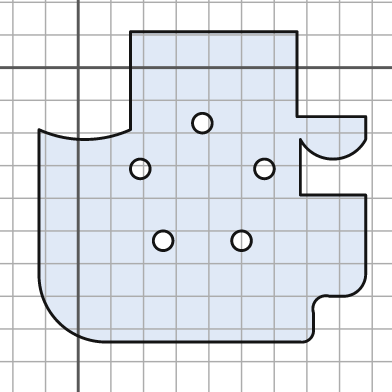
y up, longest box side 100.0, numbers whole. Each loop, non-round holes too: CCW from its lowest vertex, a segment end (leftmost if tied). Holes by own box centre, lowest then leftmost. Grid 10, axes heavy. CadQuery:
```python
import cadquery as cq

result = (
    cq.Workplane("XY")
    .moveTo(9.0, -84.0)
    .lineTo(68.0, -84.0)
    .threePointArc((71.0, -83.0), (72.0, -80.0))
    .lineTo(72.0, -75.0)
    .threePointArc((73.0, -71.0), (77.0, -70.0))
    .lineTo(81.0, -70.0)
    .threePointArc((86.0, -68.0), (88.0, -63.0))
    .lineTo(88.0, -39.0)
    .lineTo(68.0, -39.0)
    .lineTo(68.0, -22.0)
    .threePointArc((78.0, -28.0), (88.0, -22.0))
    .lineTo(88.0, -15.0)
    .lineTo(67.0, -15.0)
    .lineTo(67.0, 11.0)
    .lineTo(16.0, 11.0)
    .lineTo(16.0, -19.0)
    .threePointArc((2.0, -22.0), (-12.0, -19.0))
    .lineTo(-12.0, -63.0)
    .threePointArc((-6.0, -78.0), (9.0, -84.0))
    .close()
    .moveTo(26.0, -53.0)
    .circle(3.0)
    .moveTo(50.0, -53.0)
    .circle(3.0)
    .moveTo(19.0, -31.0)
    .circle(3.0)
    .moveTo(57.0, -31.0)
    .circle(3.0)
    .moveTo(38.0, -17.0)
    .circle(3.0)
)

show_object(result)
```